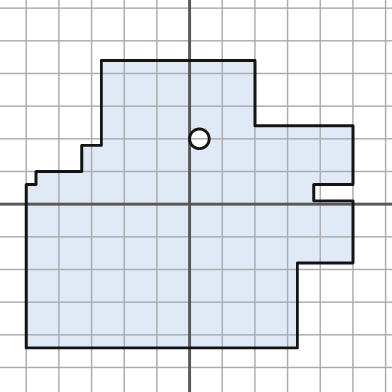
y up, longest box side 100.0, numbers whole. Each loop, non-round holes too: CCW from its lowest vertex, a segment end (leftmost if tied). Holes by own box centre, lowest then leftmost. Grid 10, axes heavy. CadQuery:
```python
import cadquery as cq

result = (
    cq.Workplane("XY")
    .moveTo(-50.0, -44.0)
    .lineTo(33.0, -44.0)
    .lineTo(33.0, -18.0)
    .lineTo(50.0, -18.0)
    .lineTo(50.0, 1.0)
    .lineTo(38.0, 1.0)
    .lineTo(38.0, 6.0)
    .lineTo(50.0, 6.0)
    .lineTo(50.0, 24.0)
    .lineTo(20.0, 24.0)
    .lineTo(20.0, 44.0)
    .lineTo(-27.0, 44.0)
    .lineTo(-27.0, 18.0)
    .lineTo(-33.0, 18.0)
    .lineTo(-33.0, 10.0)
    .lineTo(-47.0, 10.0)
    .lineTo(-47.0, 6.0)
    .lineTo(-50.0, 6.0)
    .close()
    .moveTo(3.0, 20.0)
    .circle(3.0)
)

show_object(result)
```